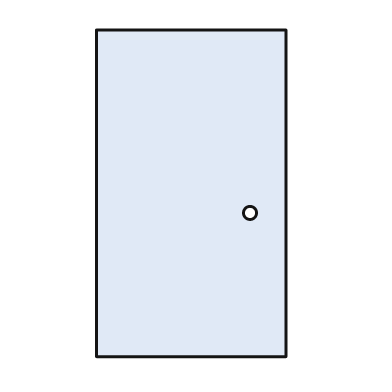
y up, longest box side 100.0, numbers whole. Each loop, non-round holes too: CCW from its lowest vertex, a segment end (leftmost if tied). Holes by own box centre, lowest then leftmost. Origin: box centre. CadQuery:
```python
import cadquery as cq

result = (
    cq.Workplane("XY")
    .moveTo(-29.0, -50.0)
    .lineTo(29.0, -50.0)
    .lineTo(29.0, 50.0)
    .lineTo(-29.0, 50.0)
    .close()
    .moveTo(18.0, -6.0)
    .circle(2.0)
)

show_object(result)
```